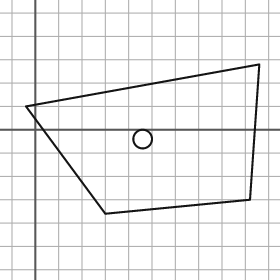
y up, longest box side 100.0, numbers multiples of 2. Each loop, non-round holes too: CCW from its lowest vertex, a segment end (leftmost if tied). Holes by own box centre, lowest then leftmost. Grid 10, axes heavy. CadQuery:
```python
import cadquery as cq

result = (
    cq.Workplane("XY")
    .moveTo(30.0, -36.0)
    .lineTo(92.0, -30.0)
    .lineTo(96.0, 28.0)
    .lineTo(-4.0, 10.0)
    .close()
    .moveTo(46.0, -4.0)
    .circle(4.0)
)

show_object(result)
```